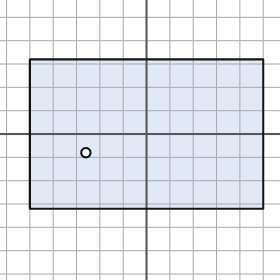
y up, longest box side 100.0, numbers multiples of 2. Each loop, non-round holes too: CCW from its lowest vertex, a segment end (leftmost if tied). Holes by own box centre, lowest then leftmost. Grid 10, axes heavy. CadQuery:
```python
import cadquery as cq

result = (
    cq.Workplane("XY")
    .moveTo(-50.0, -32.0)
    .lineTo(50.0, -32.0)
    .lineTo(50.0, 32.0)
    .lineTo(-50.0, 32.0)
    .close()
    .moveTo(-26.0, -8.0)
    .circle(2.0)
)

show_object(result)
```